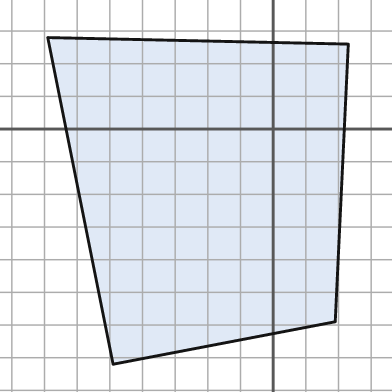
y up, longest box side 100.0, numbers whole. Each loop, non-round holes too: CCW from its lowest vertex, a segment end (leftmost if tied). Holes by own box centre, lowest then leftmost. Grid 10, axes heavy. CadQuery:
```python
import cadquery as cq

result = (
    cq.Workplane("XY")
    .moveTo(-49.0, -72.0)
    .lineTo(19.0, -59.0)
    .lineTo(23.0, 26.0)
    .lineTo(-69.0, 28.0)
    .close()
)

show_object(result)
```